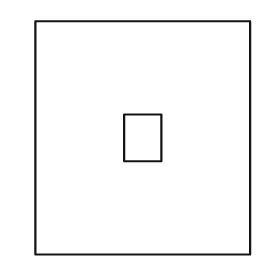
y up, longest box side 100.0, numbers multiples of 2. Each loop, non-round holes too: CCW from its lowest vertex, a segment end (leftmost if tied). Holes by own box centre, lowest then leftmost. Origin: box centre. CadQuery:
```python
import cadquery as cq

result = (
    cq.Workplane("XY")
    .moveTo(-46.0, -50.0)
    .lineTo(46.0, -50.0)
    .lineTo(46.0, 50.0)
    .lineTo(-46.0, 50.0)
    .close()
    .moveTo(-8.0, -10.0)
    .lineTo(8.0, -10.0)
    .lineTo(8.0, 10.0)
    .lineTo(-8.0, 10.0)
    .close()
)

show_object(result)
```